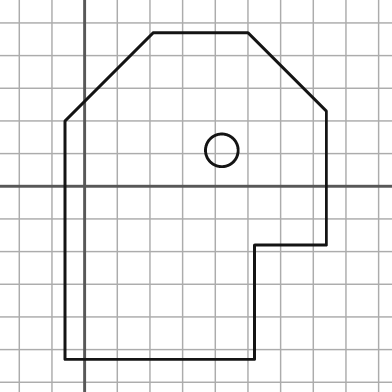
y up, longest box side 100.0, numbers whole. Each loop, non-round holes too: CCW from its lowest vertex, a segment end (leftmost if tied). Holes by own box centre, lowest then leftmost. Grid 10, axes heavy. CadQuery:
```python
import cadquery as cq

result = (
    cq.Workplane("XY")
    .moveTo(-6.0, -53.0)
    .lineTo(52.0, -53.0)
    .lineTo(52.0, -18.0)
    .lineTo(74.0, -18.0)
    .lineTo(74.0, 23.0)
    .lineTo(50.0, 47.0)
    .lineTo(21.0, 47.0)
    .lineTo(-6.0, 20.0)
    .close()
    .moveTo(42.0, 11.0)
    .circle(5.0)
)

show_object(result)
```